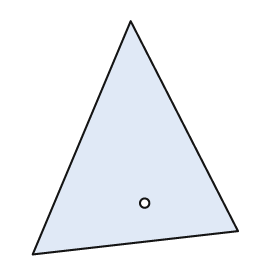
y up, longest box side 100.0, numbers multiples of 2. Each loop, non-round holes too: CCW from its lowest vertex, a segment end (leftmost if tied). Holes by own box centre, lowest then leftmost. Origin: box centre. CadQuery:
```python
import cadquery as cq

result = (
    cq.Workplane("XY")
    .moveTo(-44.0, -50.0)
    .lineTo(44.0, -40.0)
    .lineTo(-2.0, 50.0)
    .close()
    .moveTo(4.0, -28.0)
    .circle(2.0)
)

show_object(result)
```